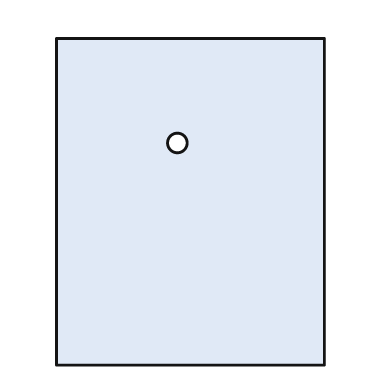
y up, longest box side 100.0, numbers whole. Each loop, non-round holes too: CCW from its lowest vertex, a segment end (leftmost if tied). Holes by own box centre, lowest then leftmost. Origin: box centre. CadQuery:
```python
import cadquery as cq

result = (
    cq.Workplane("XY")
    .moveTo(-41.0, -50.0)
    .lineTo(41.0, -50.0)
    .lineTo(41.0, 50.0)
    .lineTo(-41.0, 50.0)
    .close()
    .moveTo(-4.0, 18.0)
    .circle(3.0)
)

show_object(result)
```